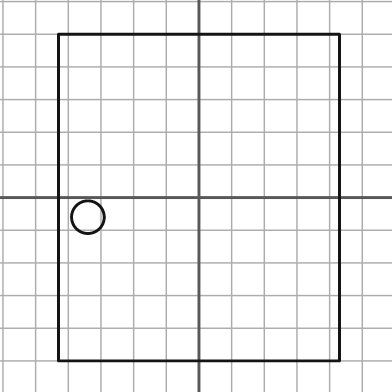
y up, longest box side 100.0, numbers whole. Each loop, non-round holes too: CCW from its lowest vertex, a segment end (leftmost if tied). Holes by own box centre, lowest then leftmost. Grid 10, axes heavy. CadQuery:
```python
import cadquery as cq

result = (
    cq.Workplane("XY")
    .moveTo(-43.0, -50.0)
    .lineTo(43.0, -50.0)
    .lineTo(43.0, 50.0)
    .lineTo(-43.0, 50.0)
    .close()
    .moveTo(-34.0, -6.0)
    .circle(5.0)
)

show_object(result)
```